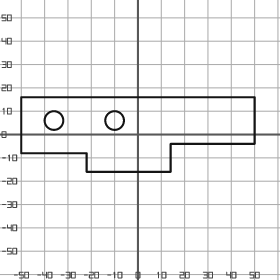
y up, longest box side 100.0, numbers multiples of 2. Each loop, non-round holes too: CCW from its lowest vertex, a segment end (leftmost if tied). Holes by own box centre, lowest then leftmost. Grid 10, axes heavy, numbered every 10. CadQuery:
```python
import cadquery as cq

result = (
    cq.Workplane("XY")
    .moveTo(-22.0, -16.0)
    .lineTo(14.0, -16.0)
    .lineTo(14.0, -4.0)
    .lineTo(50.0, -4.0)
    .lineTo(50.0, 16.0)
    .lineTo(-50.0, 16.0)
    .lineTo(-50.0, -8.0)
    .lineTo(-22.0, -8.0)
    .close()
    .moveTo(-36.0, 6.0)
    .circle(4.0)
    .moveTo(-10.0, 6.0)
    .circle(4.0)
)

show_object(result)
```